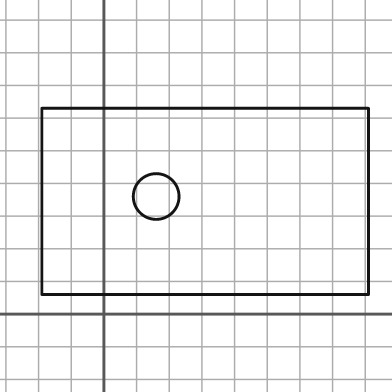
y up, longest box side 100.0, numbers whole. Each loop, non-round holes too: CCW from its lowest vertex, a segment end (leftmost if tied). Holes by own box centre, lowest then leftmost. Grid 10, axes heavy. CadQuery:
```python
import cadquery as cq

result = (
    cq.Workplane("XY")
    .moveTo(-19.0, 6.0)
    .lineTo(81.0, 6.0)
    .lineTo(81.0, 63.0)
    .lineTo(-19.0, 63.0)
    .close()
    .moveTo(16.0, 36.0)
    .circle(7.0)
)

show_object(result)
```